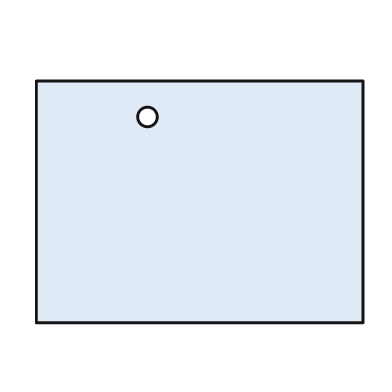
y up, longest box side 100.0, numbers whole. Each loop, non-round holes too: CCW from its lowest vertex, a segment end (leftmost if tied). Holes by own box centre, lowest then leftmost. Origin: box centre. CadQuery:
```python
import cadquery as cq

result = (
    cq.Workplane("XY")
    .moveTo(-50.0, -37.0)
    .lineTo(50.0, -37.0)
    .lineTo(50.0, 37.0)
    .lineTo(-50.0, 37.0)
    .close()
    .moveTo(-16.0, 26.0)
    .circle(3.0)
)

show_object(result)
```